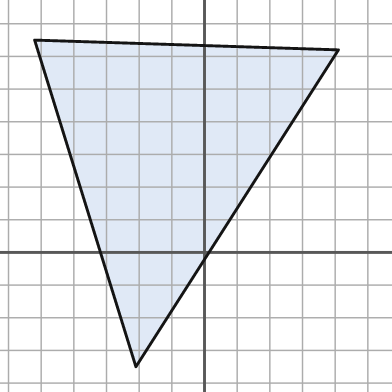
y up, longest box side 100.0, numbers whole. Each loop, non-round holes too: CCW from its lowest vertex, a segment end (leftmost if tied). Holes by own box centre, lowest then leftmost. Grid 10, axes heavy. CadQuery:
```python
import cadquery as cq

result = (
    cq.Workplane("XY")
    .moveTo(-21.0, -35.0)
    .lineTo(41.0, 62.0)
    .lineTo(-52.0, 65.0)
    .close()
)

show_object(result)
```